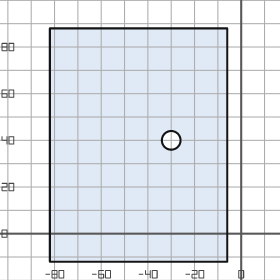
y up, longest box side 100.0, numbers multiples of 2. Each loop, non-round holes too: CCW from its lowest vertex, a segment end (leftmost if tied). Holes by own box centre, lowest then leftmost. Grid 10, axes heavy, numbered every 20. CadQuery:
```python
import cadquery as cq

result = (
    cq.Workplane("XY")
    .moveTo(-82.0, -12.0)
    .lineTo(-6.0, -12.0)
    .lineTo(-6.0, 88.0)
    .lineTo(-82.0, 88.0)
    .close()
    .moveTo(-30.0, 40.0)
    .circle(4.0)
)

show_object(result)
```